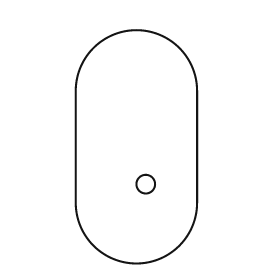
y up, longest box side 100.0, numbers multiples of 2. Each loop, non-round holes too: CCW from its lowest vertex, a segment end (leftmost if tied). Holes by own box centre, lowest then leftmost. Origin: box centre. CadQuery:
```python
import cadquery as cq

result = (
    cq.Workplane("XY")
    .moveTo(-26.0, -24.0)
    .threePointArc((0.0, -50.0), (26.0, -24.0))
    .lineTo(26.0, 24.0)
    .threePointArc((0.0, 50.0), (-26.0, 24.0))
    .close()
    .moveTo(4.0, -16.0)
    .circle(4.0)
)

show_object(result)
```